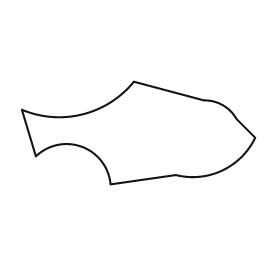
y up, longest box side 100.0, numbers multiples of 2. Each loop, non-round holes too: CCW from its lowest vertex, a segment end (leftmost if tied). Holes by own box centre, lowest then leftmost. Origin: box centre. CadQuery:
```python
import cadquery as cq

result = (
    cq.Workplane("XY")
    .moveTo(-12.0, -22.0)
    .lineTo(16.0, -18.0)
    .threePointArc((36.0, -16.0), (50.0, -2.0))
    .lineTo(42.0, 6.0)
    .threePointArc((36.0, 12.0), (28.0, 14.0))
    .lineTo(-2.0, 22.0)
    .threePointArc((-24.0, 8.0), (-50.0, 10.0))
    .lineTo(-44.0, -10.0)
    .threePointArc((-24.0, -6.0), (-12.0, -22.0))
    .close()
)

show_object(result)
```